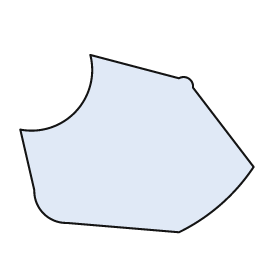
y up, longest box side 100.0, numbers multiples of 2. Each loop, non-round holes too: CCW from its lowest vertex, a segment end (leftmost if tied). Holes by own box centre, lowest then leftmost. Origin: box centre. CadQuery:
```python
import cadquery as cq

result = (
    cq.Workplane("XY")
    .moveTo(18.0, -38.0)
    .threePointArc((36.0, -26.0), (50.0, -10.0))
    .lineTo(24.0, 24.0)
    .threePointArc((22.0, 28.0), (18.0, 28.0))
    .lineTo(-20.0, 38.0)
    .threePointArc((-26.0, 14.0), (-50.0, 6.0))
    .lineTo(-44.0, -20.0)
    .threePointArc((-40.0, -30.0), (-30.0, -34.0))
    .close()
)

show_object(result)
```